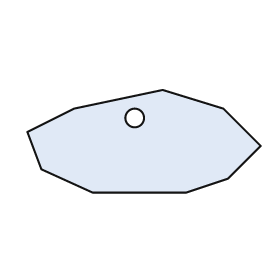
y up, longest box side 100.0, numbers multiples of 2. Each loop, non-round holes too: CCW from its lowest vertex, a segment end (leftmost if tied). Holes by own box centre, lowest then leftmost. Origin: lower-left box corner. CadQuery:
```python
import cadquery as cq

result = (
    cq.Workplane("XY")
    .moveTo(28.0, 0.0)
    .lineTo(68.0, 0.0)
    .lineTo(86.0, 6.0)
    .lineTo(100.0, 20.0)
    .lineTo(84.0, 36.0)
    .lineTo(58.0, 44.0)
    .lineTo(20.0, 36.0)
    .lineTo(0.0, 26.0)
    .lineTo(6.0, 10.0)
    .close()
    .moveTo(46.0, 32.0)
    .circle(4.0)
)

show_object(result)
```